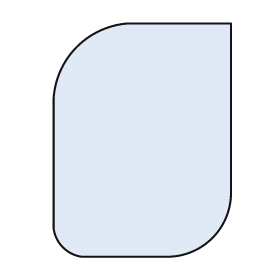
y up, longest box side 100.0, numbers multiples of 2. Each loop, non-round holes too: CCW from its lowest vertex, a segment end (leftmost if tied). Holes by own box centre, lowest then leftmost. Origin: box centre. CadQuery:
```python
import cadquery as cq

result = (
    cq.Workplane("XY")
    .moveTo(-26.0, -50.0)
    .lineTo(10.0, -50.0)
    .threePointArc((30.0, -42.0), (38.0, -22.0))
    .lineTo(38.0, 50.0)
    .lineTo(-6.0, 50.0)
    .threePointArc((-28.0, 40.0), (-38.0, 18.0))
    .lineTo(-38.0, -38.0)
    .threePointArc((-34.0, -46.0), (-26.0, -50.0))
    .close()
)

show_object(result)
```